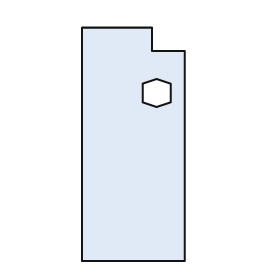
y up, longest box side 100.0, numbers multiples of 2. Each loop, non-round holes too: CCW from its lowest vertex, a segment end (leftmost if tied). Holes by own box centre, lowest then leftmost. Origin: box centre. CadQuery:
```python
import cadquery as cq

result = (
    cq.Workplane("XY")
    .moveTo(-22.0, -50.0)
    .lineTo(22.0, -50.0)
    .lineTo(22.0, 40.0)
    .lineTo(8.0, 40.0)
    .lineTo(8.0, 50.0)
    .lineTo(-22.0, 50.0)
    .close()
    .moveTo(10.0, 16.0)
    .lineTo(16.0, 18.0)
    .lineTo(16.0, 26.0)
    .lineTo(10.0, 28.0)
    .lineTo(4.0, 26.0)
    .lineTo(4.0, 18.0)
    .close()
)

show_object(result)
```